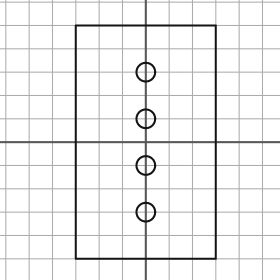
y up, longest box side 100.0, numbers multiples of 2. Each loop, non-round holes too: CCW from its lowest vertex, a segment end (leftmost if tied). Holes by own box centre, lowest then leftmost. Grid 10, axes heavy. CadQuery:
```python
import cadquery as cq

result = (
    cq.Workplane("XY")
    .moveTo(-30.0, -50.0)
    .lineTo(30.0, -50.0)
    .lineTo(30.0, 50.0)
    .lineTo(-30.0, 50.0)
    .close()
    .moveTo(0.0, -30.0)
    .circle(4.0)
    .moveTo(0.0, -10.0)
    .circle(4.0)
    .moveTo(0.0, 10.0)
    .circle(4.0)
    .moveTo(0.0, 30.0)
    .circle(4.0)
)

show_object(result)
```